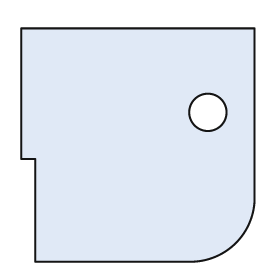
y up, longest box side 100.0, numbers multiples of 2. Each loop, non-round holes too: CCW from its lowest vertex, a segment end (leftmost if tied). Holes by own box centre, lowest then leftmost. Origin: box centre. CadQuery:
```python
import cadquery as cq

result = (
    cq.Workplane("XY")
    .moveTo(-44.0, -50.0)
    .lineTo(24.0, -50.0)
    .threePointArc((42.0, -42.0), (50.0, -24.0))
    .lineTo(50.0, 50.0)
    .lineTo(-50.0, 50.0)
    .lineTo(-50.0, -6.0)
    .lineTo(-44.0, -6.0)
    .close()
    .moveTo(30.0, 14.0)
    .circle(8.0)
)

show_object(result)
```